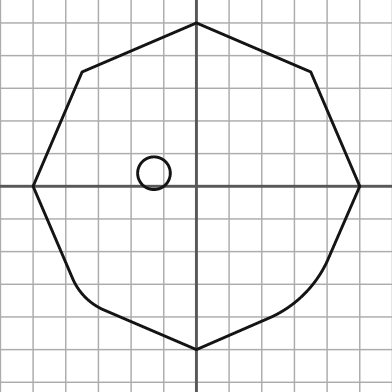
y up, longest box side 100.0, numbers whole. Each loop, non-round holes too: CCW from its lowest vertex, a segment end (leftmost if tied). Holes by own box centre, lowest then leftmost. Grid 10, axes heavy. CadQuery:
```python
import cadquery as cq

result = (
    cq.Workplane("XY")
    .moveTo(0.0, -50.0)
    .lineTo(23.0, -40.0)
    .threePointArc((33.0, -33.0), (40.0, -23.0))
    .lineTo(50.0, 0.0)
    .lineTo(35.0, 35.0)
    .lineTo(0.0, 50.0)
    .lineTo(-35.0, 35.0)
    .lineTo(-50.0, 0.0)
    .lineTo(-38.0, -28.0)
    .threePointArc((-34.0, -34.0), (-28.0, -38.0))
    .close()
    .moveTo(-13.0, 4.0)
    .circle(5.0)
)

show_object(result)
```